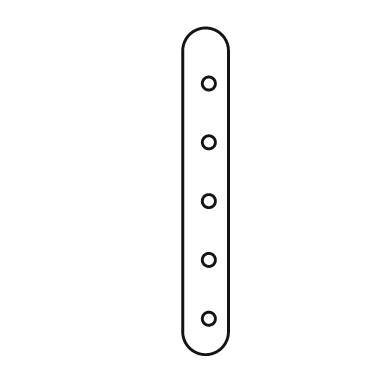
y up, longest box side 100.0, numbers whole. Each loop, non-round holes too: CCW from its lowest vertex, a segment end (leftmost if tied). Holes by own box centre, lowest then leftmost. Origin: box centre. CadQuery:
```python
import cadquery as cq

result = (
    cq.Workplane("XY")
    .moveTo(-7.0, -43.0)
    .threePointArc((0.0, -50.0), (7.0, -43.0))
    .lineTo(7.0, 43.0)
    .threePointArc((0.0, 50.0), (-7.0, 43.0))
    .close()
    .moveTo(1.0, -39.0)
    .circle(2.0)
    .moveTo(1.0, -21.0)
    .circle(2.0)
    .moveTo(1.0, -3.0)
    .circle(2.0)
    .moveTo(1.0, 15.0)
    .circle(2.0)
    .moveTo(1.0, 33.0)
    .circle(2.0)
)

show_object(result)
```